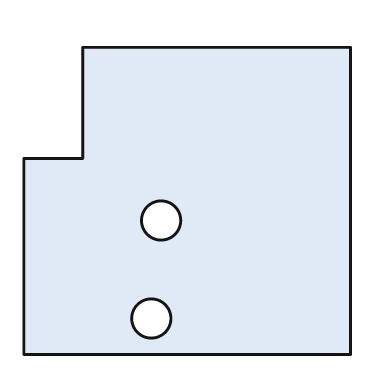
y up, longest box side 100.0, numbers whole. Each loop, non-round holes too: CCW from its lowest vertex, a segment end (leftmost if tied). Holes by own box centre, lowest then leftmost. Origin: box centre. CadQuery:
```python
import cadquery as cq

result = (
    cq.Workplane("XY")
    .moveTo(-50.0, -47.0)
    .lineTo(50.0, -47.0)
    .lineTo(50.0, 47.0)
    .lineTo(-32.0, 47.0)
    .lineTo(-32.0, 13.0)
    .lineTo(-50.0, 13.0)
    .close()
    .moveTo(-11.0, -36.0)
    .circle(6.0)
    .moveTo(-8.0, -6.0)
    .circle(6.0)
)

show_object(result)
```